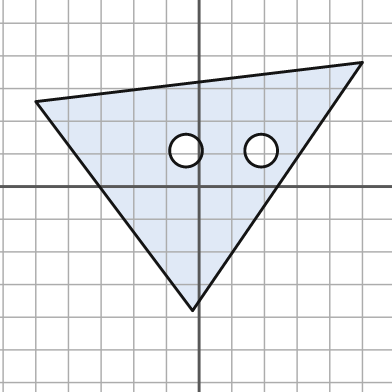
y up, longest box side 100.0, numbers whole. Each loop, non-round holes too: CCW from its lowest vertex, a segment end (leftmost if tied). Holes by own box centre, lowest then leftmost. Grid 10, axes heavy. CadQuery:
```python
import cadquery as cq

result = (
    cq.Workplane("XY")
    .moveTo(-2.0, -38.0)
    .lineTo(50.0, 38.0)
    .lineTo(-50.0, 26.0)
    .close()
    .moveTo(-4.0, 11.0)
    .circle(5.0)
    .moveTo(19.0, 11.0)
    .circle(5.0)
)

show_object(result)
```